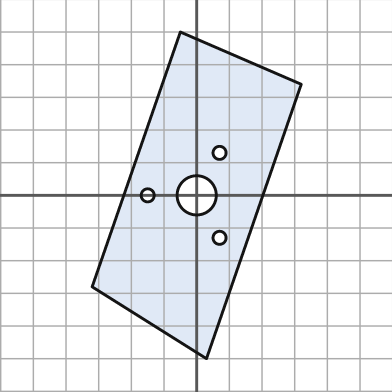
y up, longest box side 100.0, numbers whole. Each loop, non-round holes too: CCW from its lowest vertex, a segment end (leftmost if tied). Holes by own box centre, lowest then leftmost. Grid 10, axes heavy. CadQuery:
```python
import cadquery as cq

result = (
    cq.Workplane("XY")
    .moveTo(3.0, -50.0)
    .lineTo(32.0, 34.0)
    .lineTo(-5.0, 50.0)
    .lineTo(-32.0, -28.0)
    .close()
    .moveTo(7.0, -13.0)
    .circle(2.0)
    .moveTo(-15.0, 0.0)
    .circle(2.0)
    .moveTo(0.0, 0.0)
    .circle(6.0)
    .moveTo(7.0, 13.0)
    .circle(2.0)
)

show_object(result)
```